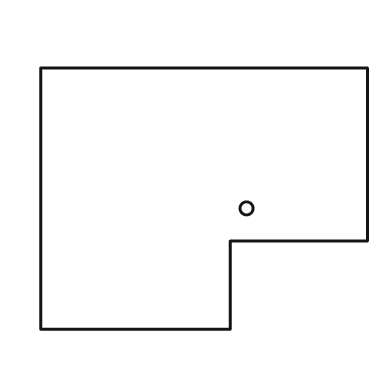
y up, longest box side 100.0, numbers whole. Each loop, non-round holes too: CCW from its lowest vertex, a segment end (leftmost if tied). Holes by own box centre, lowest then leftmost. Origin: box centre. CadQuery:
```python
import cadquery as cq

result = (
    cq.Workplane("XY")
    .moveTo(-50.0, -40.0)
    .lineTo(8.0, -40.0)
    .lineTo(8.0, -13.0)
    .lineTo(50.0, -13.0)
    .lineTo(50.0, 40.0)
    .lineTo(-50.0, 40.0)
    .close()
    .moveTo(13.0, -3.0)
    .circle(2.0)
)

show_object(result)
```